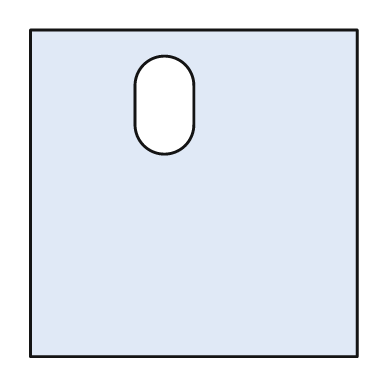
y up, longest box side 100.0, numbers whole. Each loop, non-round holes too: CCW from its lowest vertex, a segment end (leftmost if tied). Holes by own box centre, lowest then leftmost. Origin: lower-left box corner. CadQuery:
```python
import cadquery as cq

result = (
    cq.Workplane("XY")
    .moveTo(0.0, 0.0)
    .lineTo(100.0, 0.0)
    .lineTo(100.0, 100.0)
    .lineTo(0.0, 100.0)
    .close()
    .moveTo(32.0, 71.0)
    .threePointArc((41.0, 62.0), (50.0, 71.0))
    .lineTo(50.0, 83.0)
    .threePointArc((41.0, 92.0), (32.0, 83.0))
    .close()
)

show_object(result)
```